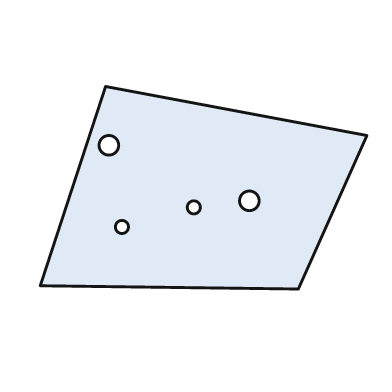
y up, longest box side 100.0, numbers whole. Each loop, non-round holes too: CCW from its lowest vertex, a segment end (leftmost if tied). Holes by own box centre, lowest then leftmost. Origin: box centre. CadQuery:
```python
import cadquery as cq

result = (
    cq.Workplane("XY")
    .moveTo(29.0, -31.0)
    .lineTo(50.0, 16.0)
    .lineTo(-30.0, 31.0)
    .lineTo(-50.0, -30.0)
    .close()
    .moveTo(-25.0, -12.0)
    .circle(2.0)
    .moveTo(-3.0, -6.0)
    .circle(2.0)
    .moveTo(14.0, -4.0)
    .circle(3.0)
    .moveTo(-29.0, 13.0)
    .circle(3.0)
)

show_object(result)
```